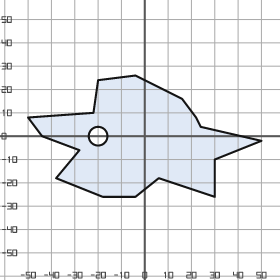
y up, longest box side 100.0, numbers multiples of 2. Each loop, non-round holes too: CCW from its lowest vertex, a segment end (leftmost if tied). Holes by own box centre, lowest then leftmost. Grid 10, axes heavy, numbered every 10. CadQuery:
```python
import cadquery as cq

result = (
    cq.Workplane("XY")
    .moveTo(-18.0, -26.0)
    .lineTo(-4.0, -26.0)
    .lineTo(6.0, -18.0)
    .lineTo(30.0, -26.0)
    .lineTo(30.0, -10.0)
    .lineTo(50.0, -2.0)
    .lineTo(24.0, 4.0)
    .lineTo(22.0, 8.0)
    .lineTo(16.0, 16.0)
    .lineTo(-4.0, 26.0)
    .lineTo(-20.0, 24.0)
    .lineTo(-22.0, 10.0)
    .lineTo(-50.0, 8.0)
    .lineTo(-44.0, 0.0)
    .lineTo(-28.0, -6.0)
    .lineTo(-38.0, -18.0)
    .close()
    .moveTo(-20.0, 0.0)
    .circle(4.0)
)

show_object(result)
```